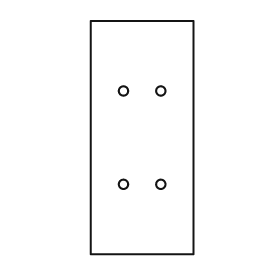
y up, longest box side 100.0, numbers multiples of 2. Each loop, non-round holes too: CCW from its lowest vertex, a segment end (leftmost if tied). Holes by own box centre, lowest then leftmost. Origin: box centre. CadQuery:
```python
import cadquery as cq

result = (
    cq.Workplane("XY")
    .moveTo(-22.0, -50.0)
    .lineTo(22.0, -50.0)
    .lineTo(22.0, 50.0)
    .lineTo(-22.0, 50.0)
    .close()
    .moveTo(-8.0, -20.0)
    .circle(2.0)
    .moveTo(8.0, -20.0)
    .circle(2.0)
    .moveTo(-8.0, 20.0)
    .circle(2.0)
    .moveTo(8.0, 20.0)
    .circle(2.0)
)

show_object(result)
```